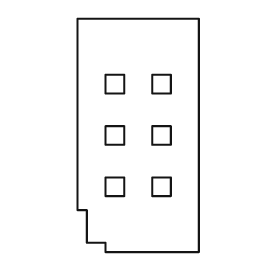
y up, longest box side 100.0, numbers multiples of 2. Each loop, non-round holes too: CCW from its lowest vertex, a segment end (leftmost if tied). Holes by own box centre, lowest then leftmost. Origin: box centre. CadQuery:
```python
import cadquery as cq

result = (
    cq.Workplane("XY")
    .moveTo(-14.0, -50.0)
    .lineTo(26.0, -50.0)
    .lineTo(26.0, 50.0)
    .lineTo(-26.0, 50.0)
    .lineTo(-26.0, -32.0)
    .lineTo(-22.0, -32.0)
    .lineTo(-22.0, -46.0)
    .lineTo(-14.0, -46.0)
    .close()
    .moveTo(-14.0, -26.0)
    .lineTo(-6.0, -26.0)
    .lineTo(-6.0, -18.0)
    .lineTo(-14.0, -18.0)
    .close()
    .moveTo(6.0, -26.0)
    .lineTo(14.0, -26.0)
    .lineTo(14.0, -18.0)
    .lineTo(6.0, -18.0)
    .close()
    .moveTo(-14.0, -4.0)
    .lineTo(-6.0, -4.0)
    .lineTo(-6.0, 4.0)
    .lineTo(-14.0, 4.0)
    .close()
    .moveTo(6.0, -4.0)
    .lineTo(14.0, -4.0)
    .lineTo(14.0, 4.0)
    .lineTo(6.0, 4.0)
    .close()
    .moveTo(-14.0, 18.0)
    .lineTo(-6.0, 18.0)
    .lineTo(-6.0, 26.0)
    .lineTo(-14.0, 26.0)
    .close()
    .moveTo(6.0, 18.0)
    .lineTo(14.0, 18.0)
    .lineTo(14.0, 26.0)
    .lineTo(6.0, 26.0)
    .close()
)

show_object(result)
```